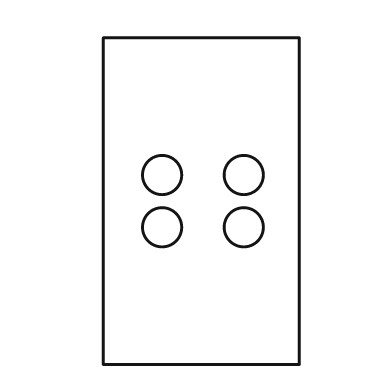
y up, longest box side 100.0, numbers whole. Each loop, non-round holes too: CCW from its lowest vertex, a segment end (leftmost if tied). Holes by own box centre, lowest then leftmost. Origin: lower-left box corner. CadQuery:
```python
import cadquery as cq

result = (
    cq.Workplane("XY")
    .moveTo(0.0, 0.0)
    .lineTo(60.0, 0.0)
    .lineTo(60.0, 100.0)
    .lineTo(0.0, 100.0)
    .close()
    .moveTo(18.0, 42.0)
    .circle(6.0)
    .moveTo(43.0, 42.0)
    .circle(6.0)
    .moveTo(18.0, 58.0)
    .circle(6.0)
    .moveTo(43.0, 58.0)
    .circle(6.0)
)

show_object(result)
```